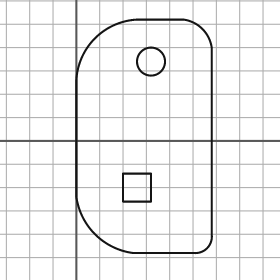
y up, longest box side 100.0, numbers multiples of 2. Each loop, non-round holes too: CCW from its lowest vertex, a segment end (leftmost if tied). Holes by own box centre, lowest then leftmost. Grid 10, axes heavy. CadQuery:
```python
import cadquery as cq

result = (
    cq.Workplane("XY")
    .moveTo(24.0, -48.0)
    .lineTo(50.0, -48.0)
    .threePointArc((56.0, -46.0), (58.0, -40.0))
    .lineTo(58.0, 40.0)
    .threePointArc((54.0, 48.0), (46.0, 52.0))
    .lineTo(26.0, 52.0)
    .threePointArc((8.0, 44.0), (0.0, 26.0))
    .lineTo(0.0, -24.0)
    .threePointArc((8.0, -40.0), (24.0, -48.0))
    .close()
    .moveTo(20.0, -26.0)
    .lineTo(32.0, -26.0)
    .lineTo(32.0, -14.0)
    .lineTo(20.0, -14.0)
    .close()
    .moveTo(32.0, 34.0)
    .circle(6.0)
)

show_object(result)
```